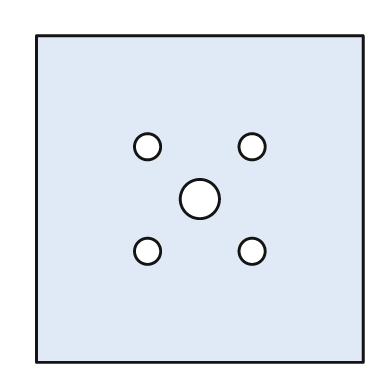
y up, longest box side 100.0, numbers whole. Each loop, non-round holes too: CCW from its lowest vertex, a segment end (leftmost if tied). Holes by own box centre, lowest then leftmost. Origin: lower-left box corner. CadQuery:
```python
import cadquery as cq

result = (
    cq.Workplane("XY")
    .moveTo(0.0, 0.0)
    .lineTo(100.0, 0.0)
    .lineTo(100.0, 100.0)
    .lineTo(0.0, 100.0)
    .close()
    .moveTo(34.0, 34.0)
    .circle(4.0)
    .moveTo(66.0, 34.0)
    .circle(4.0)
    .moveTo(50.0, 50.0)
    .circle(6.0)
    .moveTo(34.0, 66.0)
    .circle(4.0)
    .moveTo(66.0, 66.0)
    .circle(4.0)
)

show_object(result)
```